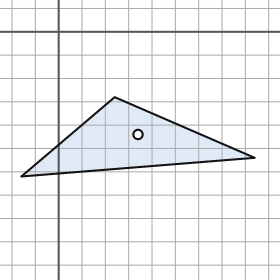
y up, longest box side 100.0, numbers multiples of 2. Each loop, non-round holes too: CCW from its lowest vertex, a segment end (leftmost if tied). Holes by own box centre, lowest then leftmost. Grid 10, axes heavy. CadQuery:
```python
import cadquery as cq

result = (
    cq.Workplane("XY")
    .moveTo(-16.0, -62.0)
    .lineTo(84.0, -54.0)
    .lineTo(24.0, -28.0)
    .close()
    .moveTo(34.0, -44.0)
    .circle(2.0)
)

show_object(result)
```